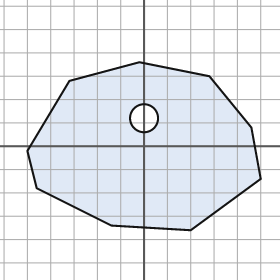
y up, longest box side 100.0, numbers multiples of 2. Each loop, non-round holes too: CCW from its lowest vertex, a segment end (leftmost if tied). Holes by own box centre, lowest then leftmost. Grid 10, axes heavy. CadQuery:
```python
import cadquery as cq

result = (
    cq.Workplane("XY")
    .moveTo(20.0, -36.0)
    .lineTo(50.0, -14.0)
    .lineTo(46.0, 8.0)
    .lineTo(28.0, 30.0)
    .lineTo(-2.0, 36.0)
    .lineTo(-32.0, 28.0)
    .lineTo(-50.0, -2.0)
    .lineTo(-46.0, -18.0)
    .lineTo(-14.0, -34.0)
    .close()
    .moveTo(0.0, 12.0)
    .circle(6.0)
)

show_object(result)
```